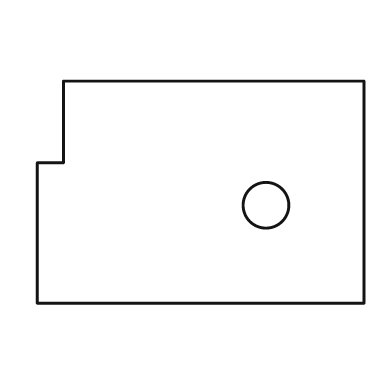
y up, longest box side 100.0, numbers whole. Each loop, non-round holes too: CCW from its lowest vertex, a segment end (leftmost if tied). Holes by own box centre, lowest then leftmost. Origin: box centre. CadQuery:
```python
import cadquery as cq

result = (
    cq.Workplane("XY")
    .moveTo(-50.0, -34.0)
    .lineTo(50.0, -34.0)
    .lineTo(50.0, 34.0)
    .lineTo(-42.0, 34.0)
    .lineTo(-42.0, 9.0)
    .lineTo(-50.0, 9.0)
    .close()
    .moveTo(20.0, -4.0)
    .circle(7.0)
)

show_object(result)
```